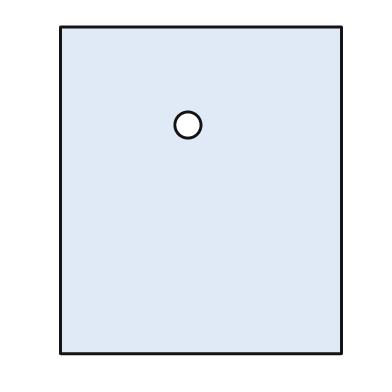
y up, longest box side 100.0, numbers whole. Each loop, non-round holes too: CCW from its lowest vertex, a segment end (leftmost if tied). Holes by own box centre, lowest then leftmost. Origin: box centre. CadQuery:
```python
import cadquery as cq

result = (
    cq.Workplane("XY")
    .moveTo(-43.0, -50.0)
    .lineTo(43.0, -50.0)
    .lineTo(43.0, 50.0)
    .lineTo(-43.0, 50.0)
    .close()
    .moveTo(-4.0, 20.0)
    .circle(4.0)
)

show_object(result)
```